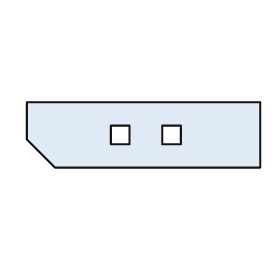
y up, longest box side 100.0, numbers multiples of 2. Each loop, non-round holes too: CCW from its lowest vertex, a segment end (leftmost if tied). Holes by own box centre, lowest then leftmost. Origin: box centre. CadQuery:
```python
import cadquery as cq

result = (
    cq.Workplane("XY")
    .moveTo(-38.0, -14.0)
    .lineTo(50.0, -14.0)
    .lineTo(50.0, 14.0)
    .lineTo(-50.0, 14.0)
    .lineTo(-50.0, -2.0)
    .close()
    .moveTo(-14.0, -4.0)
    .lineTo(-6.0, -4.0)
    .lineTo(-6.0, 4.0)
    .lineTo(-14.0, 4.0)
    .close()
    .moveTo(8.0, -4.0)
    .lineTo(16.0, -4.0)
    .lineTo(16.0, 4.0)
    .lineTo(8.0, 4.0)
    .close()
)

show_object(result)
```